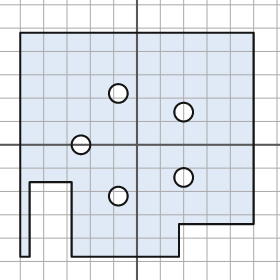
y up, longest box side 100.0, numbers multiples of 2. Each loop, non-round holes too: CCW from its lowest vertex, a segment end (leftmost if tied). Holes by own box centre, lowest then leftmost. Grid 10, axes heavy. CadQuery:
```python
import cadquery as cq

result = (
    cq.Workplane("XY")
    .moveTo(-50.0, -48.0)
    .lineTo(-46.0, -48.0)
    .lineTo(-46.0, -16.0)
    .lineTo(-28.0, -16.0)
    .lineTo(-28.0, -48.0)
    .lineTo(18.0, -48.0)
    .lineTo(18.0, -34.0)
    .lineTo(50.0, -34.0)
    .lineTo(50.0, 48.0)
    .lineTo(-50.0, 48.0)
    .close()
    .moveTo(-8.0, -22.0)
    .circle(4.0)
    .moveTo(20.0, -14.0)
    .circle(4.0)
    .moveTo(-24.0, 0.0)
    .circle(4.0)
    .moveTo(20.0, 14.0)
    .circle(4.0)
    .moveTo(-8.0, 22.0)
    .circle(4.0)
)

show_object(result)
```